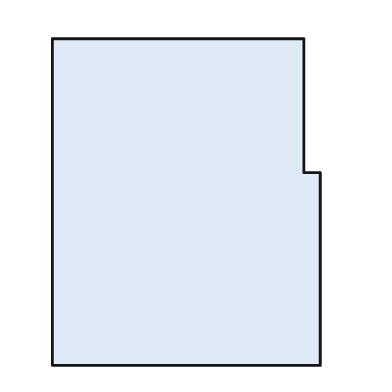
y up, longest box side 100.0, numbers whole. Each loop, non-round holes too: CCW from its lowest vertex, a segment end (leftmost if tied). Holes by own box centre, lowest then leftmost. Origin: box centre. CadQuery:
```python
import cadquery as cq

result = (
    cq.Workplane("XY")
    .moveTo(-41.0, -50.0)
    .lineTo(41.0, -50.0)
    .lineTo(41.0, 9.0)
    .lineTo(36.0, 9.0)
    .lineTo(36.0, 50.0)
    .lineTo(-41.0, 50.0)
    .close()
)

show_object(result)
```